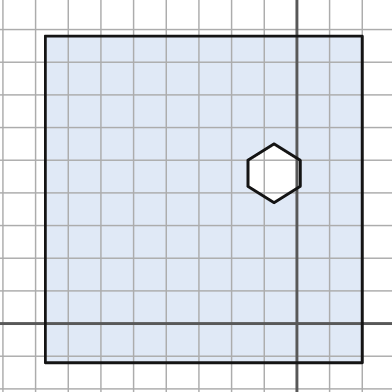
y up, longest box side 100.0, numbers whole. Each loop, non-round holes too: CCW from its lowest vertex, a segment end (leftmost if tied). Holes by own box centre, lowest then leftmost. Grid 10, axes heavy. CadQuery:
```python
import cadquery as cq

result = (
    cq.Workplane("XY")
    .moveTo(-77.0, -12.0)
    .lineTo(20.0, -12.0)
    .lineTo(20.0, 88.0)
    .lineTo(-77.0, 88.0)
    .close()
    .moveTo(-7.0, 37.0)
    .lineTo(1.0, 42.0)
    .lineTo(1.0, 50.0)
    .lineTo(-7.0, 55.0)
    .lineTo(-15.0, 50.0)
    .lineTo(-15.0, 42.0)
    .close()
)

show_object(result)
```